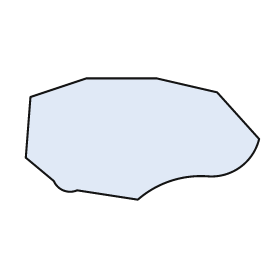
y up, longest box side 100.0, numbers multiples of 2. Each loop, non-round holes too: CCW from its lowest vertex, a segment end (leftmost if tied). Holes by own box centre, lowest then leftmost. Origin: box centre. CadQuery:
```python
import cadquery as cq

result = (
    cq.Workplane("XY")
    .moveTo(-2.0, -26.0)
    .threePointArc((12.0, -18.0), (28.0, -16.0))
    .threePointArc((42.0, -12.0), (50.0, 0.0))
    .lineTo(32.0, 20.0)
    .lineTo(6.0, 26.0)
    .lineTo(-24.0, 26.0)
    .lineTo(-48.0, 18.0)
    .lineTo(-50.0, -8.0)
    .lineTo(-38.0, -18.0)
    .threePointArc((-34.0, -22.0), (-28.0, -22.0))
    .close()
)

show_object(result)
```